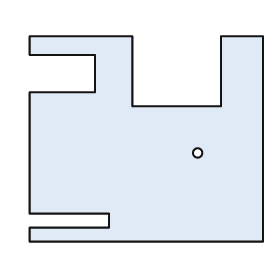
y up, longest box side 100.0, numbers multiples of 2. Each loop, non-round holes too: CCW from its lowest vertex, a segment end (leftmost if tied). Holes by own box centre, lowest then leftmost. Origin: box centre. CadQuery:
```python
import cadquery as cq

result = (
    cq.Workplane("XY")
    .moveTo(-50.0, -44.0)
    .lineTo(50.0, -44.0)
    .lineTo(50.0, 44.0)
    .lineTo(32.0, 44.0)
    .lineTo(32.0, 14.0)
    .lineTo(-6.0, 14.0)
    .lineTo(-6.0, 44.0)
    .lineTo(-50.0, 44.0)
    .lineTo(-50.0, 36.0)
    .lineTo(-22.0, 36.0)
    .lineTo(-22.0, 20.0)
    .lineTo(-50.0, 20.0)
    .lineTo(-50.0, -32.0)
    .lineTo(-16.0, -32.0)
    .lineTo(-16.0, -38.0)
    .lineTo(-50.0, -38.0)
    .close()
    .moveTo(22.0, -6.0)
    .circle(2.0)
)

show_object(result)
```